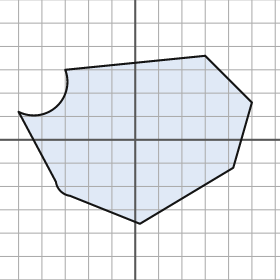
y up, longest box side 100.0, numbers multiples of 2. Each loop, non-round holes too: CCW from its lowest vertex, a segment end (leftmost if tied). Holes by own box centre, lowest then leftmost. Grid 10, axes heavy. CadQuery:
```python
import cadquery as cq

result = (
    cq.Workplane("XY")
    .moveTo(2.0, -36.0)
    .lineTo(42.0, -12.0)
    .lineTo(50.0, 16.0)
    .lineTo(30.0, 36.0)
    .lineTo(-30.0, 30.0)
    .threePointArc((-34.0, 14.0), (-50.0, 12.0))
    .lineTo(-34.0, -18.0)
    .threePointArc((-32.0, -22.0), (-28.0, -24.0))
    .close()
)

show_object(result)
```